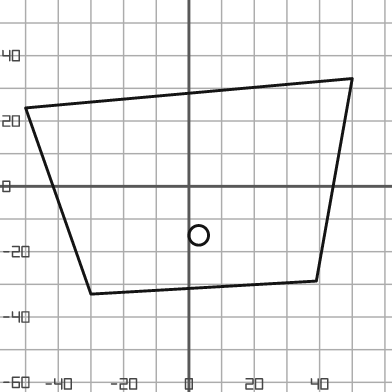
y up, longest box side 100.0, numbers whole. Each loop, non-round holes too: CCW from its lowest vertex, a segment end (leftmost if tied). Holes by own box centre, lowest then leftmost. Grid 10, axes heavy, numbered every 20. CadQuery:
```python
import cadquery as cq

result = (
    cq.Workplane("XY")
    .moveTo(-30.0, -33.0)
    .lineTo(39.0, -29.0)
    .lineTo(50.0, 33.0)
    .lineTo(-50.0, 24.0)
    .close()
    .moveTo(3.0, -15.0)
    .circle(3.0)
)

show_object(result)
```